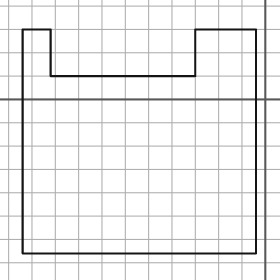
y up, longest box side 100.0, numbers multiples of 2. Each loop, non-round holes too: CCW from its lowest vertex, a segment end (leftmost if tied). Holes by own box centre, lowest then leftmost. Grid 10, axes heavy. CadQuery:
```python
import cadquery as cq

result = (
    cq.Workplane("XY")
    .moveTo(-104.0, -66.0)
    .lineTo(-4.0, -66.0)
    .lineTo(-4.0, 30.0)
    .lineTo(-30.0, 30.0)
    .lineTo(-30.0, 10.0)
    .lineTo(-92.0, 10.0)
    .lineTo(-92.0, 30.0)
    .lineTo(-104.0, 30.0)
    .close()
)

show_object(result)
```